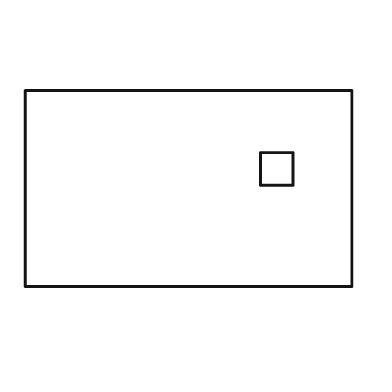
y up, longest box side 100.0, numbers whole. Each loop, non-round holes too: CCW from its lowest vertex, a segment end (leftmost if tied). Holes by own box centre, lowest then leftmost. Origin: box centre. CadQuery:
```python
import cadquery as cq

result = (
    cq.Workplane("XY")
    .moveTo(-50.0, -30.0)
    .lineTo(50.0, -30.0)
    .lineTo(50.0, 30.0)
    .lineTo(-50.0, 30.0)
    .close()
    .moveTo(22.0, 1.0)
    .lineTo(32.0, 1.0)
    .lineTo(32.0, 11.0)
    .lineTo(22.0, 11.0)
    .close()
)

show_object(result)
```